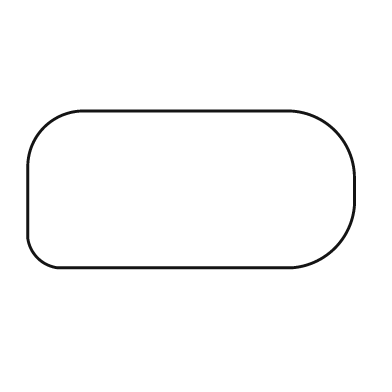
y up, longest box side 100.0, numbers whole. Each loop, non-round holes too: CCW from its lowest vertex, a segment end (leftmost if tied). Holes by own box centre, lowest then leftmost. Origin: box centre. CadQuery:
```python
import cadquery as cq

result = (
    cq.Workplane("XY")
    .moveTo(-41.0, -24.0)
    .lineTo(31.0, -24.0)
    .threePointArc((44.0, -18.0), (50.0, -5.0))
    .lineTo(50.0, 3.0)
    .threePointArc((44.0, 18.0), (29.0, 24.0))
    .lineTo(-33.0, 24.0)
    .threePointArc((-45.0, 19.0), (-50.0, 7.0))
    .lineTo(-50.0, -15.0)
    .threePointArc((-47.0, -21.0), (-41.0, -24.0))
    .close()
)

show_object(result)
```